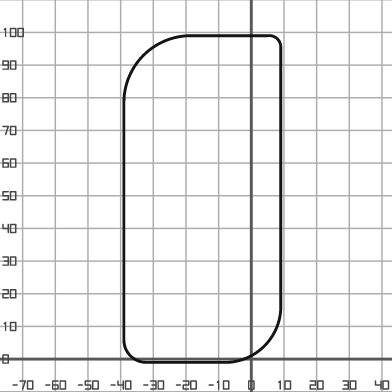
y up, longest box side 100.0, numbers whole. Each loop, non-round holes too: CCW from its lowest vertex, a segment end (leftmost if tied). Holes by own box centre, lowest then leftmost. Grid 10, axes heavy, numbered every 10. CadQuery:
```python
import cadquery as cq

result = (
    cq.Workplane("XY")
    .moveTo(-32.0, -1.0)
    .lineTo(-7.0, -1.0)
    .threePointArc((4.0, 4.0), (9.0, 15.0))
    .lineTo(9.0, 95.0)
    .threePointArc((8.0, 98.0), (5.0, 99.0))
    .lineTo(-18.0, 99.0)
    .threePointArc((-33.0, 93.0), (-39.0, 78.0))
    .lineTo(-39.0, 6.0)
    .threePointArc((-37.0, 1.0), (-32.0, -1.0))
    .close()
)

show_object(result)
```